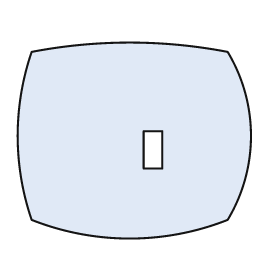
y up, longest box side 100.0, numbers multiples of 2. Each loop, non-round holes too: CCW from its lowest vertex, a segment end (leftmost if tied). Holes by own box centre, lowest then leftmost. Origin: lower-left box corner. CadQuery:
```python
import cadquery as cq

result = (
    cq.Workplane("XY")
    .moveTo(6.0, 8.0)
    .threePointArc((48.0, 0.0), (90.0, 8.0))
    .threePointArc((100.0, 44.0), (90.0, 80.0))
    .threePointArc((48.0, 84.0), (6.0, 80.0))
    .threePointArc((0.0, 44.0), (6.0, 8.0))
    .close()
    .moveTo(54.0, 30.0)
    .lineTo(62.0, 30.0)
    .lineTo(62.0, 46.0)
    .lineTo(54.0, 46.0)
    .close()
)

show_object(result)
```